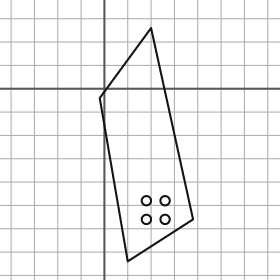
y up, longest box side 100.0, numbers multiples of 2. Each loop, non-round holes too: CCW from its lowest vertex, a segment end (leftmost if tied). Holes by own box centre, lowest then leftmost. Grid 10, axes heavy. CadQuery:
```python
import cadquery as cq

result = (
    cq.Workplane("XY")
    .moveTo(10.0, -74.0)
    .lineTo(38.0, -56.0)
    .lineTo(20.0, 26.0)
    .lineTo(-2.0, -4.0)
    .close()
    .moveTo(18.0, -56.0)
    .circle(2.0)
    .moveTo(26.0, -56.0)
    .circle(2.0)
    .moveTo(18.0, -48.0)
    .circle(2.0)
    .moveTo(26.0, -48.0)
    .circle(2.0)
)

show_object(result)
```